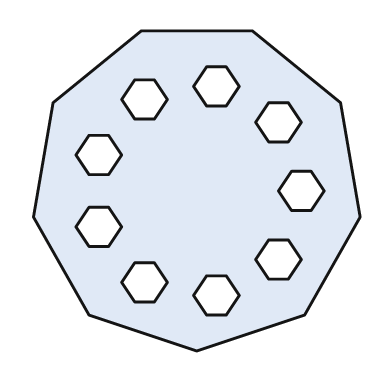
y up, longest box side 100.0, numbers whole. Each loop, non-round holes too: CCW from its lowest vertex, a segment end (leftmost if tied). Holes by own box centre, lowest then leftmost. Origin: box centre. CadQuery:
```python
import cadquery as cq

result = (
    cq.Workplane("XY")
    .moveTo(0.0, -49.0)
    .lineTo(33.0, -38.0)
    .lineTo(50.0, -8.0)
    .lineTo(44.0, 27.0)
    .lineTo(17.0, 49.0)
    .lineTo(-17.0, 49.0)
    .lineTo(-44.0, 27.0)
    .lineTo(-50.0, -8.0)
    .lineTo(-33.0, -38.0)
    .close()
    .moveTo(3.0, -38.0)
    .lineTo(9.0, -38.0)
    .lineTo(13.0, -32.0)
    .lineTo(9.0, -26.0)
    .lineTo(3.0, -26.0)
    .lineTo(-1.0, -32.0)
    .close()
    .moveTo(-19.0, -34.0)
    .lineTo(-13.0, -34.0)
    .lineTo(-9.0, -28.0)
    .lineTo(-13.0, -22.0)
    .lineTo(-19.0, -22.0)
    .lineTo(-23.0, -28.0)
    .close()
    .moveTo(22.0, -27.0)
    .lineTo(28.0, -27.0)
    .lineTo(32.0, -21.0)
    .lineTo(28.0, -15.0)
    .lineTo(22.0, -15.0)
    .lineTo(18.0, -21.0)
    .close()
    .moveTo(-33.0, -17.0)
    .lineTo(-27.0, -17.0)
    .lineTo(-23.0, -11.0)
    .lineTo(-27.0, -5.0)
    .lineTo(-33.0, -5.0)
    .lineTo(-37.0, -11.0)
    .close()
    .moveTo(29.0, -6.0)
    .lineTo(35.0, -6.0)
    .lineTo(39.0, 0.0)
    .lineTo(35.0, 6.0)
    .lineTo(29.0, 6.0)
    .lineTo(25.0, 0.0)
    .close()
    .moveTo(-33.0, 5.0)
    .lineTo(-27.0, 5.0)
    .lineTo(-23.0, 11.0)
    .lineTo(-27.0, 17.0)
    .lineTo(-33.0, 17.0)
    .lineTo(-37.0, 11.0)
    .close()
    .moveTo(22.0, 15.0)
    .lineTo(28.0, 15.0)
    .lineTo(32.0, 21.0)
    .lineTo(28.0, 27.0)
    .lineTo(22.0, 27.0)
    .lineTo(18.0, 21.0)
    .close()
    .moveTo(-19.0, 22.0)
    .lineTo(-13.0, 22.0)
    .lineTo(-9.0, 28.0)
    .lineTo(-13.0, 34.0)
    .lineTo(-19.0, 34.0)
    .lineTo(-23.0, 28.0)
    .close()
    .moveTo(3.0, 26.0)
    .lineTo(9.0, 26.0)
    .lineTo(13.0, 32.0)
    .lineTo(9.0, 38.0)
    .lineTo(3.0, 38.0)
    .lineTo(-1.0, 32.0)
    .close()
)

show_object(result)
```